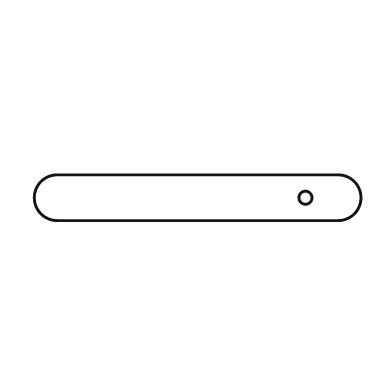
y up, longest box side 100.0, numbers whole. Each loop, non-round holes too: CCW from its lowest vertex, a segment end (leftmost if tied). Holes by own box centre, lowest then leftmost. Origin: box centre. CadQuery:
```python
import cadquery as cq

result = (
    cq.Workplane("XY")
    .moveTo(-43.0, -7.0)
    .lineTo(43.0, -7.0)
    .threePointArc((50.0, 0.0), (43.0, 7.0))
    .lineTo(-43.0, 7.0)
    .threePointArc((-50.0, 0.0), (-43.0, -7.0))
    .close()
    .moveTo(33.0, 0.0)
    .circle(2.0)
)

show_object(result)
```